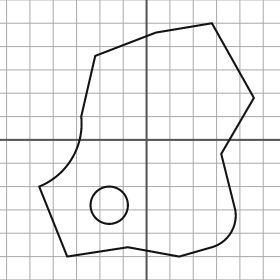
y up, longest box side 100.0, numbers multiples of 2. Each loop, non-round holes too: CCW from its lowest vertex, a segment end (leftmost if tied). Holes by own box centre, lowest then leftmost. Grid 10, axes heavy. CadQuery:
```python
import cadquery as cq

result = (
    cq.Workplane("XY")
    .moveTo(-34.0, -50.0)
    .lineTo(-8.0, -46.0)
    .lineTo(14.0, -50.0)
    .lineTo(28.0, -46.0)
    .threePointArc((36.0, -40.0), (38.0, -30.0))
    .lineTo(32.0, -6.0)
    .lineTo(46.0, 18.0)
    .lineTo(28.0, 50.0)
    .lineTo(4.0, 46.0)
    .lineTo(-22.0, 36.0)
    .lineTo(-28.0, 10.0)
    .threePointArc((-32.0, -8.0), (-46.0, -20.0))
    .close()
    .moveTo(-16.0, -28.0)
    .circle(8.0)
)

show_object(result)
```